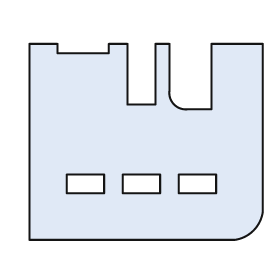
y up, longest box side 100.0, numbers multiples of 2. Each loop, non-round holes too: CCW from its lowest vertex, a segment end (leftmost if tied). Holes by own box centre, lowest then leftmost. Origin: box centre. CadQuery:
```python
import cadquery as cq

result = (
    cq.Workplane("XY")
    .moveTo(-50.0, -42.0)
    .lineTo(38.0, -42.0)
    .threePointArc((46.0, -38.0), (50.0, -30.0))
    .lineTo(50.0, 42.0)
    .lineTo(28.0, 42.0)
    .lineTo(28.0, 14.0)
    .lineTo(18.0, 14.0)
    .threePointArc((12.0, 16.0), (10.0, 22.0))
    .lineTo(10.0, 42.0)
    .lineTo(4.0, 42.0)
    .lineTo(4.0, 16.0)
    .lineTo(-8.0, 16.0)
    .lineTo(-8.0, 42.0)
    .lineTo(-16.0, 42.0)
    .lineTo(-16.0, 38.0)
    .lineTo(-38.0, 38.0)
    .lineTo(-38.0, 42.0)
    .lineTo(-50.0, 42.0)
    .close()
    .moveTo(-34.0, -22.0)
    .lineTo(-18.0, -22.0)
    .lineTo(-18.0, -14.0)
    .lineTo(-34.0, -14.0)
    .close()
    .moveTo(-10.0, -22.0)
    .lineTo(6.0, -22.0)
    .lineTo(6.0, -14.0)
    .lineTo(-10.0, -14.0)
    .close()
    .moveTo(14.0, -22.0)
    .lineTo(30.0, -22.0)
    .lineTo(30.0, -14.0)
    .lineTo(14.0, -14.0)
    .close()
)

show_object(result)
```